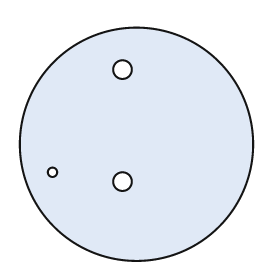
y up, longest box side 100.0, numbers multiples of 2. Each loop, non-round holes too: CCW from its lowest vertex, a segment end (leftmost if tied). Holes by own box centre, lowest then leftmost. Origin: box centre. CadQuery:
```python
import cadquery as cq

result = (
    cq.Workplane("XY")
    .moveTo(0.0, 0.0)
    .circle(50.0)
    .moveTo(-6.0, -16.0)
    .circle(4.0)
    .moveTo(-36.0, -12.0)
    .circle(2.0)
    .moveTo(-6.0, 32.0)
    .circle(4.0)
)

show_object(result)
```